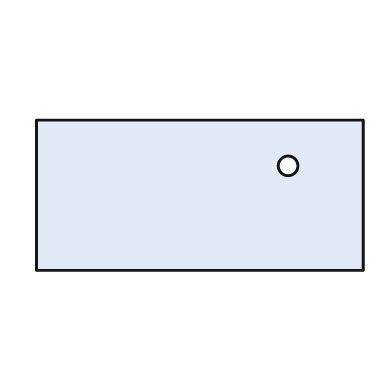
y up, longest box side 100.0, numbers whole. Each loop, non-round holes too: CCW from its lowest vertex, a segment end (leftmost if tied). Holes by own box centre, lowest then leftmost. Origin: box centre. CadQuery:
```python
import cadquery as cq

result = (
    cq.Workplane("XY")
    .moveTo(-50.0, -23.0)
    .lineTo(50.0, -23.0)
    .lineTo(50.0, 23.0)
    .lineTo(-50.0, 23.0)
    .close()
    .moveTo(27.0, 9.0)
    .circle(3.0)
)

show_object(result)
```